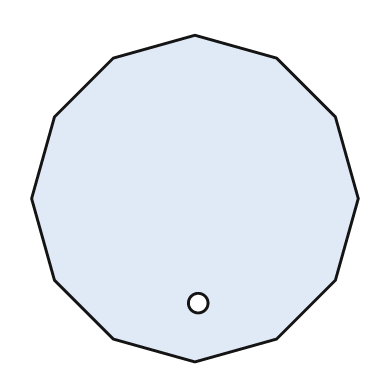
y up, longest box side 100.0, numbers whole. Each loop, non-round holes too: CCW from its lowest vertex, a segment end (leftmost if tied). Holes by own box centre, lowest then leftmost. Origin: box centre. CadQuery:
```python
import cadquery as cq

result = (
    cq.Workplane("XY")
    .moveTo(0.0, -50.0)
    .lineTo(25.0, -43.0)
    .lineTo(43.0, -25.0)
    .lineTo(50.0, 0.0)
    .lineTo(43.0, 25.0)
    .lineTo(25.0, 43.0)
    .lineTo(0.0, 50.0)
    .lineTo(-25.0, 43.0)
    .lineTo(-43.0, 25.0)
    .lineTo(-50.0, 0.0)
    .lineTo(-43.0, -25.0)
    .lineTo(-25.0, -43.0)
    .close()
    .moveTo(1.0, -32.0)
    .circle(3.0)
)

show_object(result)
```